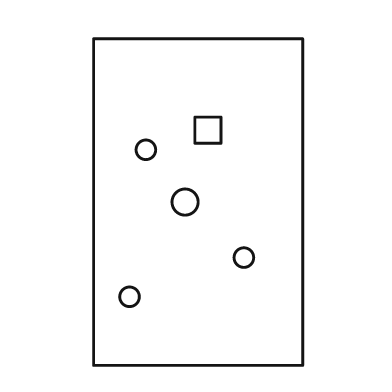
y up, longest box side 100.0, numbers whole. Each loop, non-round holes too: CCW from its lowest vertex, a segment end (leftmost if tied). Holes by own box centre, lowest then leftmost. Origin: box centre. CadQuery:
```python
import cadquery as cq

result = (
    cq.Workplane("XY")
    .moveTo(-32.0, -50.0)
    .lineTo(32.0, -50.0)
    .lineTo(32.0, 50.0)
    .lineTo(-32.0, 50.0)
    .close()
    .moveTo(-21.0, -29.0)
    .circle(3.0)
    .moveTo(14.0, -17.0)
    .circle(3.0)
    .moveTo(-4.0, 0.0)
    .circle(4.0)
    .moveTo(-16.0, 16.0)
    .circle(3.0)
    .moveTo(-1.0, 18.0)
    .lineTo(7.0, 18.0)
    .lineTo(7.0, 26.0)
    .lineTo(-1.0, 26.0)
    .close()
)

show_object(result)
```